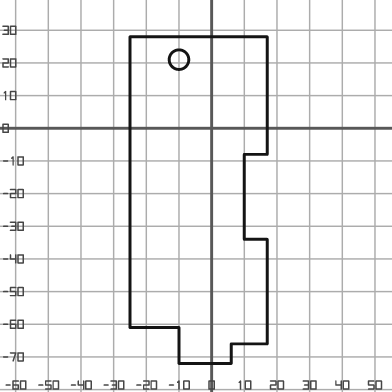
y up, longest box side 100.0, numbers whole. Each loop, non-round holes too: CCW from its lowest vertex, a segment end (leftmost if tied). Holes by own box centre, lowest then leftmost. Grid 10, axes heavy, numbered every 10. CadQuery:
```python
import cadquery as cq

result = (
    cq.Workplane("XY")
    .moveTo(-10.0, -72.0)
    .lineTo(6.0, -72.0)
    .lineTo(6.0, -66.0)
    .lineTo(17.0, -66.0)
    .lineTo(17.0, -34.0)
    .lineTo(10.0, -34.0)
    .lineTo(10.0, -8.0)
    .lineTo(17.0, -8.0)
    .lineTo(17.0, 28.0)
    .lineTo(-25.0, 28.0)
    .lineTo(-25.0, -61.0)
    .lineTo(-10.0, -61.0)
    .close()
    .moveTo(-10.0, 21.0)
    .circle(3.0)
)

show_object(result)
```